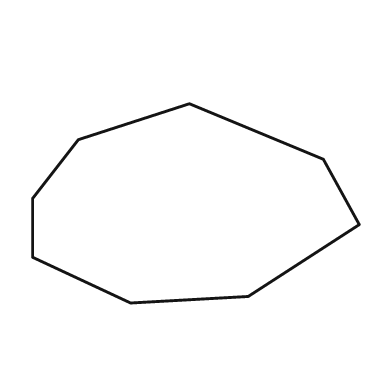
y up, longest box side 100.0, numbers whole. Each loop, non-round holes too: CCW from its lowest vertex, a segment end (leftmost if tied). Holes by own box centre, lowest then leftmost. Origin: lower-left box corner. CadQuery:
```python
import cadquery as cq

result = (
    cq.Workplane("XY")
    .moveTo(30.0, 0.0)
    .lineTo(66.0, 2.0)
    .lineTo(100.0, 24.0)
    .lineTo(89.0, 44.0)
    .lineTo(48.0, 61.0)
    .lineTo(14.0, 50.0)
    .lineTo(0.0, 32.0)
    .lineTo(0.0, 14.0)
    .close()
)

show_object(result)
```